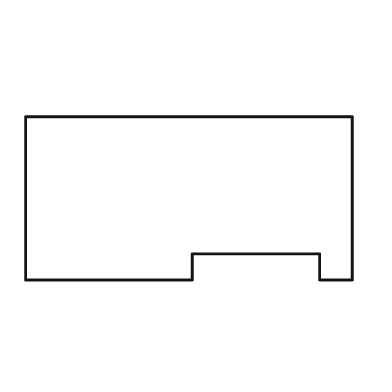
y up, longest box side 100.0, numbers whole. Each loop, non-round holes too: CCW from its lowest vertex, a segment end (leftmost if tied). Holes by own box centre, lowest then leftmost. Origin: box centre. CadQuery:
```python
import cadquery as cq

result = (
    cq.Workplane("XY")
    .moveTo(-50.0, -25.0)
    .lineTo(1.0, -25.0)
    .lineTo(1.0, -17.0)
    .lineTo(40.0, -17.0)
    .lineTo(40.0, -25.0)
    .lineTo(50.0, -25.0)
    .lineTo(50.0, 25.0)
    .lineTo(-50.0, 25.0)
    .close()
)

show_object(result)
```